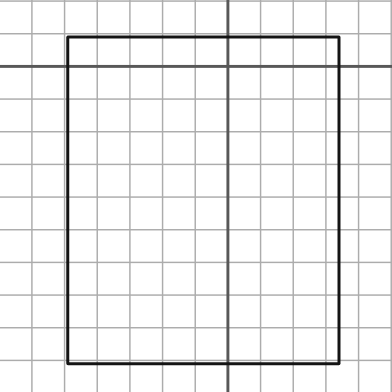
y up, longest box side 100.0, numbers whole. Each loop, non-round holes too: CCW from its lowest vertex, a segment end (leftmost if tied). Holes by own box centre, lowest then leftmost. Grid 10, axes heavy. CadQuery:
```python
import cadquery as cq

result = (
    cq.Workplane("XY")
    .moveTo(-49.0, -91.0)
    .lineTo(34.0, -91.0)
    .lineTo(34.0, 9.0)
    .lineTo(-49.0, 9.0)
    .close()
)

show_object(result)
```